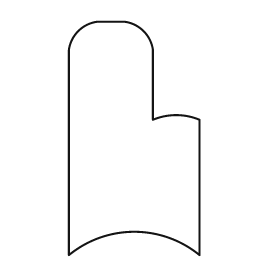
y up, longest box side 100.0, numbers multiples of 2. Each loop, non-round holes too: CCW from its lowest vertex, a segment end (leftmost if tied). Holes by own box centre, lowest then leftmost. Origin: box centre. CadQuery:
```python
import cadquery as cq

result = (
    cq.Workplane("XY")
    .moveTo(-28.0, -50.0)
    .threePointArc((0.0, -40.0), (28.0, -50.0))
    .lineTo(28.0, 8.0)
    .threePointArc((18.0, 10.0), (8.0, 8.0))
    .lineTo(8.0, 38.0)
    .threePointArc((4.0, 46.0), (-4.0, 50.0))
    .lineTo(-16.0, 50.0)
    .threePointArc((-24.0, 46.0), (-28.0, 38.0))
    .close()
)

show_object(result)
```